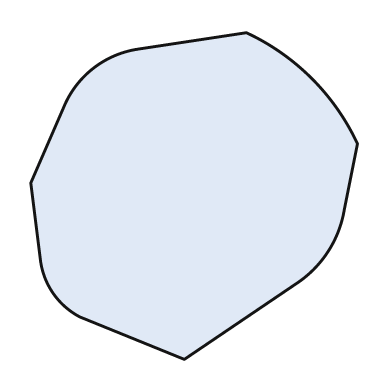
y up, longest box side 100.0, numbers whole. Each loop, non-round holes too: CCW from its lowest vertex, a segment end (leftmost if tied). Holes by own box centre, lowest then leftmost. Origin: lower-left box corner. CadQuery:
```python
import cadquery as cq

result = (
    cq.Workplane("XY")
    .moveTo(47.0, 0.0)
    .lineTo(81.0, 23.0)
    .threePointArc((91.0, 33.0), (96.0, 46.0))
    .lineTo(100.0, 66.0)
    .threePointArc((86.0, 86.0), (66.0, 100.0))
    .lineTo(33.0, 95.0)
    .threePointArc((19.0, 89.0), (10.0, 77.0))
    .lineTo(0.0, 54.0)
    .lineTo(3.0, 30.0)
    .threePointArc((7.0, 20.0), (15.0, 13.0))
    .close()
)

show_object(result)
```